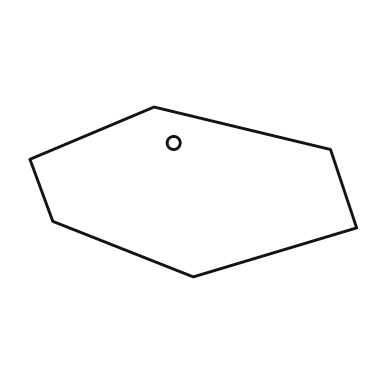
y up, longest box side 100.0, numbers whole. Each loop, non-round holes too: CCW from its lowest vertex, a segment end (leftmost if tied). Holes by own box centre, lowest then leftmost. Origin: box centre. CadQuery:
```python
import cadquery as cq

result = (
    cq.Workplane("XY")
    .moveTo(0.0, -26.0)
    .lineTo(50.0, -11.0)
    .lineTo(42.0, 13.0)
    .lineTo(-12.0, 26.0)
    .lineTo(-50.0, 10.0)
    .lineTo(-43.0, -9.0)
    .close()
    .moveTo(-6.0, 15.0)
    .circle(2.0)
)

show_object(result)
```